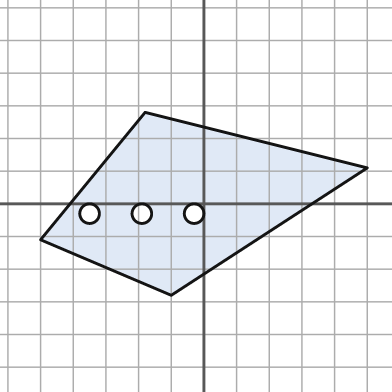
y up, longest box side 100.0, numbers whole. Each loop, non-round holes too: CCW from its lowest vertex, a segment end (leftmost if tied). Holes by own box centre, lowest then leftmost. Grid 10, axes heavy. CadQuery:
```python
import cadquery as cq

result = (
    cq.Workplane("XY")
    .moveTo(-10.0, -28.0)
    .lineTo(50.0, 11.0)
    .lineTo(-18.0, 28.0)
    .lineTo(-50.0, -11.0)
    .close()
    .moveTo(-35.0, -3.0)
    .circle(3.0)
    .moveTo(-19.0, -3.0)
    .circle(3.0)
    .moveTo(-3.0, -3.0)
    .circle(3.0)
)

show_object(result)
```